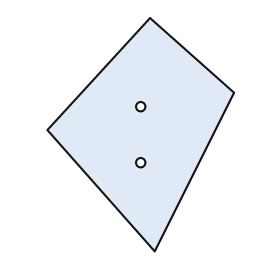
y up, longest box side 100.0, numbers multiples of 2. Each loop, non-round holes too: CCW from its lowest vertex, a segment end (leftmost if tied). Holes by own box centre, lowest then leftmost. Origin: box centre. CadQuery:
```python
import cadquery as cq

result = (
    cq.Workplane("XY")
    .moveTo(6.0, -50.0)
    .lineTo(40.0, 18.0)
    .lineTo(4.0, 50.0)
    .lineTo(-40.0, 2.0)
    .close()
    .moveTo(0.0, -12.0)
    .circle(2.0)
    .moveTo(0.0, 12.0)
    .circle(2.0)
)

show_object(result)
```